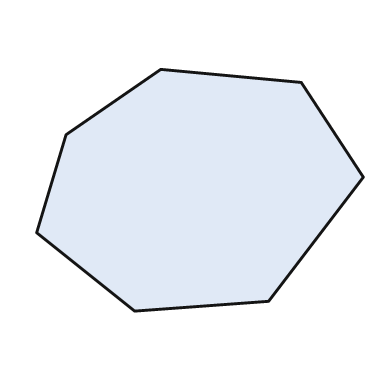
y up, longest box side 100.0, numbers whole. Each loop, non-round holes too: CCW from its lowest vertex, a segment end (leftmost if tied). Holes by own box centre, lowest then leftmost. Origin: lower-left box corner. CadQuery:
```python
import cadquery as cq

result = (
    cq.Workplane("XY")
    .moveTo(30.0, 0.0)
    .lineTo(71.0, 3.0)
    .lineTo(100.0, 41.0)
    .lineTo(81.0, 70.0)
    .lineTo(38.0, 74.0)
    .lineTo(9.0, 54.0)
    .lineTo(0.0, 24.0)
    .close()
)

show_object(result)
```